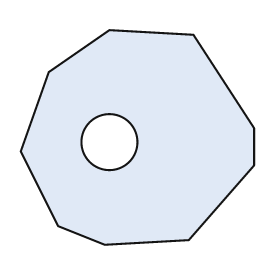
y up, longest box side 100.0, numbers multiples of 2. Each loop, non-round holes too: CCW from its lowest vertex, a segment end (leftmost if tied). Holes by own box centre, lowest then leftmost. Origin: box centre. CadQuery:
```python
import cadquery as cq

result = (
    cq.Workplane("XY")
    .moveTo(-14.0, -46.0)
    .lineTo(22.0, -44.0)
    .lineTo(50.0, -12.0)
    .lineTo(50.0, 4.0)
    .lineTo(24.0, 44.0)
    .lineTo(-12.0, 46.0)
    .lineTo(-38.0, 28.0)
    .lineTo(-50.0, -6.0)
    .lineTo(-34.0, -38.0)
    .close()
    .moveTo(-12.0, -2.0)
    .circle(12.0)
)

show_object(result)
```